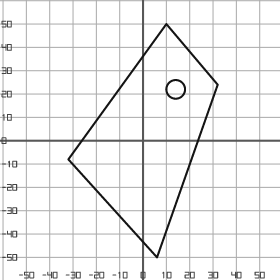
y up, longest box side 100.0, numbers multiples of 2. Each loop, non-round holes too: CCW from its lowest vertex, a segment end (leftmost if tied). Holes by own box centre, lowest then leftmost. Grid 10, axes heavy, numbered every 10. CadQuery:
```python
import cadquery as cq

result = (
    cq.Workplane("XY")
    .moveTo(6.0, -50.0)
    .lineTo(32.0, 24.0)
    .lineTo(10.0, 50.0)
    .lineTo(-32.0, -8.0)
    .close()
    .moveTo(14.0, 22.0)
    .circle(4.0)
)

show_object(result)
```